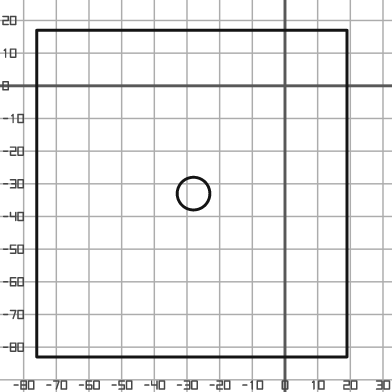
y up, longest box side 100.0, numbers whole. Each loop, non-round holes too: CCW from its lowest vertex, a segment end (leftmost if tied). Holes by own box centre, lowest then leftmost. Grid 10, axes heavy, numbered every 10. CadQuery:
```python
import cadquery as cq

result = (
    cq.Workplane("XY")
    .moveTo(-76.0, -83.0)
    .lineTo(19.0, -83.0)
    .lineTo(19.0, 17.0)
    .lineTo(-76.0, 17.0)
    .close()
    .moveTo(-28.0, -33.0)
    .circle(5.0)
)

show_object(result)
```